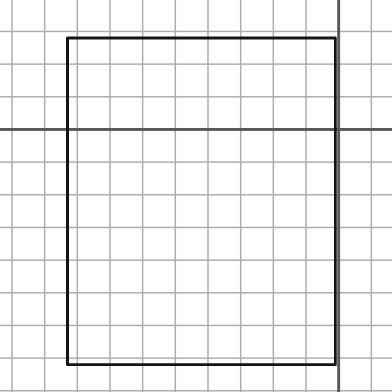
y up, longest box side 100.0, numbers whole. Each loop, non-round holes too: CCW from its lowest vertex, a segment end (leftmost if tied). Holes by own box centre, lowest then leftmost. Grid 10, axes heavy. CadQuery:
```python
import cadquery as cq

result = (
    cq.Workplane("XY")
    .moveTo(-83.0, -72.0)
    .lineTo(-1.0, -72.0)
    .lineTo(-1.0, 28.0)
    .lineTo(-83.0, 28.0)
    .close()
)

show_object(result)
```